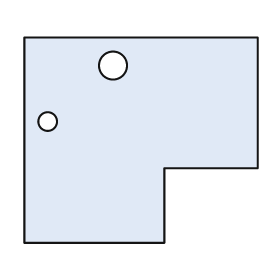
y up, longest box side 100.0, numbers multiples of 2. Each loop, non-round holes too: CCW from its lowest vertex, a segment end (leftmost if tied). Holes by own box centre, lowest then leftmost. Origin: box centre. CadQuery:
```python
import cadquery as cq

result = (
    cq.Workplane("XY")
    .moveTo(-50.0, -44.0)
    .lineTo(10.0, -44.0)
    .lineTo(10.0, -12.0)
    .lineTo(50.0, -12.0)
    .lineTo(50.0, 44.0)
    .lineTo(-50.0, 44.0)
    .close()
    .moveTo(-40.0, 8.0)
    .circle(4.0)
    .moveTo(-12.0, 32.0)
    .circle(6.0)
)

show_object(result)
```